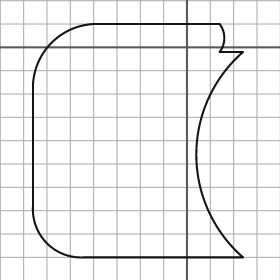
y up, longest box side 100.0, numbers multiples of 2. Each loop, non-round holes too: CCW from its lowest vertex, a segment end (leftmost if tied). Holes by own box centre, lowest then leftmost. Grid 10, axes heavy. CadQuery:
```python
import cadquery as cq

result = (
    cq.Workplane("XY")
    .moveTo(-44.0, -90.0)
    .lineTo(24.0, -90.0)
    .threePointArc((4.0, -46.0), (24.0, -2.0))
    .lineTo(14.0, -2.0)
    .threePointArc((16.0, 4.0), (14.0, 10.0))
    .lineTo(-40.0, 10.0)
    .threePointArc((-58.0, 2.0), (-66.0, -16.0))
    .lineTo(-66.0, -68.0)
    .threePointArc((-60.0, -84.0), (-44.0, -90.0))
    .close()
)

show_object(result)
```